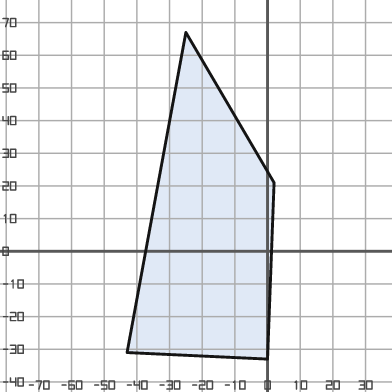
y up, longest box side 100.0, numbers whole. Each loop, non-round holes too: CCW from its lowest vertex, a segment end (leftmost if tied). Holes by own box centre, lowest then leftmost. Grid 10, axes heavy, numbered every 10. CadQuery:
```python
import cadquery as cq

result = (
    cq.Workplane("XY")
    .moveTo(0.0, -33.0)
    .lineTo(2.0, 21.0)
    .lineTo(-25.0, 67.0)
    .lineTo(-43.0, -31.0)
    .close()
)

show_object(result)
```